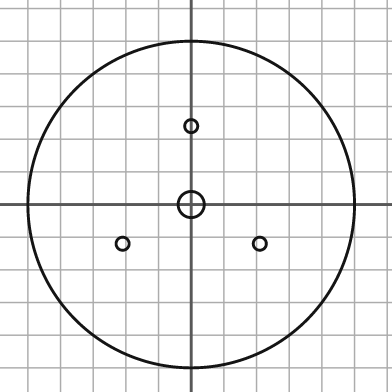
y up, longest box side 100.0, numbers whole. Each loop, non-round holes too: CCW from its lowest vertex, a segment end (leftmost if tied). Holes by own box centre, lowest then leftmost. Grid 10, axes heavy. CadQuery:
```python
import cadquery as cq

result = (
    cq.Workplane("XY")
    .moveTo(0.0, 0.0)
    .circle(50.0)
    .moveTo(-21.0, -12.0)
    .circle(2.0)
    .moveTo(21.0, -12.0)
    .circle(2.0)
    .moveTo(0.0, 0.0)
    .circle(4.0)
    .moveTo(0.0, 24.0)
    .circle(2.0)
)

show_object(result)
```